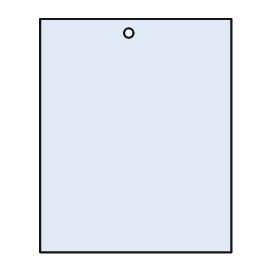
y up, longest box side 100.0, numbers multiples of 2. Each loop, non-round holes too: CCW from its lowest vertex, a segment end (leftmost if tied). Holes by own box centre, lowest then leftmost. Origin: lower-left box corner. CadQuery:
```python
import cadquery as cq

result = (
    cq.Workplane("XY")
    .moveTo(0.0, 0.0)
    .lineTo(82.0, 0.0)
    .lineTo(82.0, 100.0)
    .lineTo(0.0, 100.0)
    .close()
    .moveTo(38.0, 94.0)
    .circle(2.0)
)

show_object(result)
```